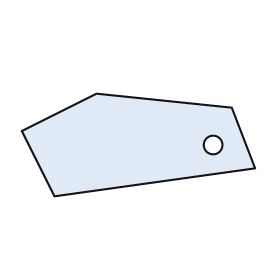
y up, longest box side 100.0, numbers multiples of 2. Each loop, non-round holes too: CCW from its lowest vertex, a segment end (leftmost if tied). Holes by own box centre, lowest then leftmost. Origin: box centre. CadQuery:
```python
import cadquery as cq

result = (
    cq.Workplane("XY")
    .moveTo(-36.0, -22.0)
    .lineTo(50.0, -10.0)
    .lineTo(40.0, 16.0)
    .lineTo(-18.0, 22.0)
    .lineTo(-50.0, 6.0)
    .close()
    .moveTo(32.0, 0.0)
    .circle(4.0)
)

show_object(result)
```